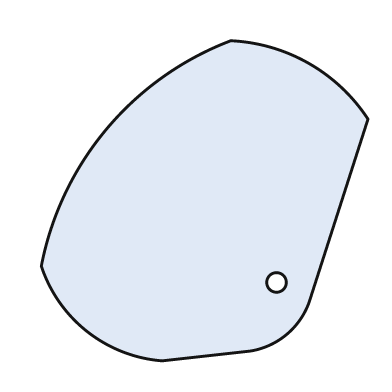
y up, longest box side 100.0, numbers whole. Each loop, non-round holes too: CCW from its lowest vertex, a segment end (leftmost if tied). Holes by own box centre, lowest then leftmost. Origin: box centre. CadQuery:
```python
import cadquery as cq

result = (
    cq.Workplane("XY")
    .moveTo(-13.0, -49.0)
    .lineTo(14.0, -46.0)
    .threePointArc((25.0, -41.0), (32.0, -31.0))
    .lineTo(50.0, 25.0)
    .threePointArc((32.0, 42.0), (8.0, 49.0))
    .threePointArc((-30.0, 22.0), (-50.0, -20.0))
    .threePointArc((-36.0, -40.0), (-13.0, -49.0))
    .close()
    .moveTo(22.0, -25.0)
    .circle(3.0)
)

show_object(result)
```